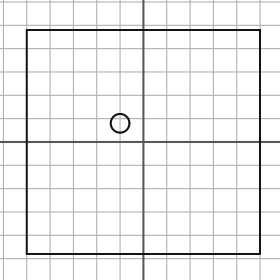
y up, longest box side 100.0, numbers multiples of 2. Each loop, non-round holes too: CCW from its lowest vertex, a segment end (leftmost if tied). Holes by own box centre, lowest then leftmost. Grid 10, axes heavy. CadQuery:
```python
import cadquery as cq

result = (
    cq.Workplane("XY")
    .moveTo(-50.0, -48.0)
    .lineTo(50.0, -48.0)
    .lineTo(50.0, 48.0)
    .lineTo(-50.0, 48.0)
    .close()
    .moveTo(-10.0, 8.0)
    .circle(4.0)
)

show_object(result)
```